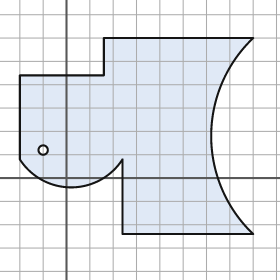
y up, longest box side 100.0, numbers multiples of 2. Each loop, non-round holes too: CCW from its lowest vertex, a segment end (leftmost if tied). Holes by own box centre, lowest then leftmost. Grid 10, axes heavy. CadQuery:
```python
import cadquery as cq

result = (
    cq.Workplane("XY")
    .moveTo(24.0, -24.0)
    .lineTo(80.0, -24.0)
    .threePointArc((62.0, 18.0), (80.0, 60.0))
    .lineTo(16.0, 60.0)
    .lineTo(16.0, 44.0)
    .lineTo(-20.0, 44.0)
    .lineTo(-20.0, 8.0)
    .threePointArc((2.0, -4.0), (24.0, 8.0))
    .close()
    .moveTo(-10.0, 12.0)
    .circle(2.0)
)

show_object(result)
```